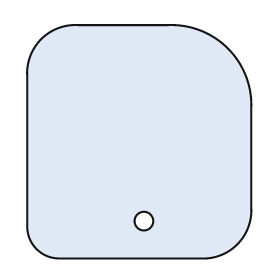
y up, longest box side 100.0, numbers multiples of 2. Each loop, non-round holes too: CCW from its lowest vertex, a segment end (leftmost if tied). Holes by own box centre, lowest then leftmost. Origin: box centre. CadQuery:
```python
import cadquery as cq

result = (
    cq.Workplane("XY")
    .moveTo(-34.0, -50.0)
    .lineTo(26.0, -50.0)
    .threePointArc((42.0, -44.0), (48.0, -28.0))
    .lineTo(48.0, 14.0)
    .threePointArc((38.0, 40.0), (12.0, 50.0))
    .lineTo(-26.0, 50.0)
    .threePointArc((-42.0, 44.0), (-48.0, 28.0))
    .lineTo(-48.0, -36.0)
    .threePointArc((-44.0, -46.0), (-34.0, -50.0))
    .close()
    .moveTo(2.0, -34.0)
    .circle(4.0)
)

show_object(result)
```